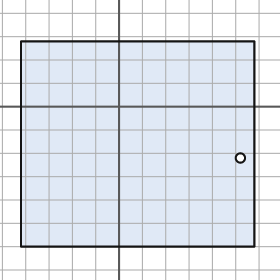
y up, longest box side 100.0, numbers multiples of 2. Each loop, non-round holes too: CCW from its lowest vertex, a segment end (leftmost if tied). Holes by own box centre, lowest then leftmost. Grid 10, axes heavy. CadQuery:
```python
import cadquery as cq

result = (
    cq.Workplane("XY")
    .moveTo(-42.0, -60.0)
    .lineTo(58.0, -60.0)
    .lineTo(58.0, 28.0)
    .lineTo(-42.0, 28.0)
    .close()
    .moveTo(52.0, -22.0)
    .circle(2.0)
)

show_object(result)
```